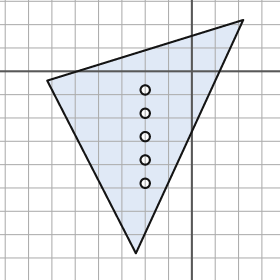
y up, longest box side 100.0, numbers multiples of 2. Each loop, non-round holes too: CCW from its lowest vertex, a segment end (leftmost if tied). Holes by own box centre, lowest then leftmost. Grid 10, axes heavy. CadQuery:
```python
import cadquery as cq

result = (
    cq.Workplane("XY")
    .moveTo(-24.0, -78.0)
    .lineTo(22.0, 22.0)
    .lineTo(-62.0, -4.0)
    .close()
    .moveTo(-20.0, -48.0)
    .circle(2.0)
    .moveTo(-20.0, -38.0)
    .circle(2.0)
    .moveTo(-20.0, -28.0)
    .circle(2.0)
    .moveTo(-20.0, -18.0)
    .circle(2.0)
    .moveTo(-20.0, -8.0)
    .circle(2.0)
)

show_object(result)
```